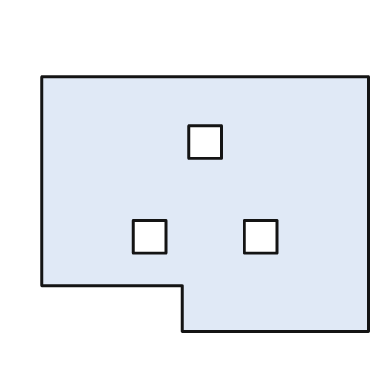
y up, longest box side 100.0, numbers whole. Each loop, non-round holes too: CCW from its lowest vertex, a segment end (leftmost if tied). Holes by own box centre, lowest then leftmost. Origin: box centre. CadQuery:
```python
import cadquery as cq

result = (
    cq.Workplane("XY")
    .moveTo(-7.0, -39.0)
    .lineTo(50.0, -39.0)
    .lineTo(50.0, 39.0)
    .lineTo(-50.0, 39.0)
    .lineTo(-50.0, -25.0)
    .lineTo(-7.0, -25.0)
    .close()
    .moveTo(-22.0, -15.0)
    .lineTo(-12.0, -15.0)
    .lineTo(-12.0, -5.0)
    .lineTo(-22.0, -5.0)
    .close()
    .moveTo(12.0, -15.0)
    .lineTo(22.0, -15.0)
    .lineTo(22.0, -5.0)
    .lineTo(12.0, -5.0)
    .close()
    .moveTo(-5.0, 14.0)
    .lineTo(5.0, 14.0)
    .lineTo(5.0, 24.0)
    .lineTo(-5.0, 24.0)
    .close()
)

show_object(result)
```